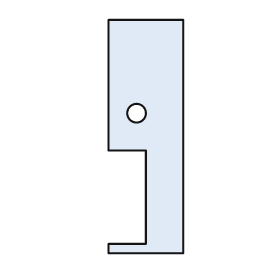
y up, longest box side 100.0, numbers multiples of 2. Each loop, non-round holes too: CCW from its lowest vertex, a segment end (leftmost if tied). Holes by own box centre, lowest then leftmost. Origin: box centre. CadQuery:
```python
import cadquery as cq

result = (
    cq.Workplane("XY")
    .moveTo(-16.0, -50.0)
    .lineTo(16.0, -50.0)
    .lineTo(16.0, 50.0)
    .lineTo(-16.0, 50.0)
    .lineTo(-16.0, -6.0)
    .lineTo(0.0, -6.0)
    .lineTo(0.0, -46.0)
    .lineTo(-16.0, -46.0)
    .close()
    .moveTo(-4.0, 10.0)
    .circle(4.0)
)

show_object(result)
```